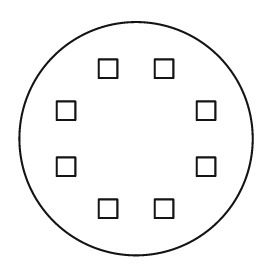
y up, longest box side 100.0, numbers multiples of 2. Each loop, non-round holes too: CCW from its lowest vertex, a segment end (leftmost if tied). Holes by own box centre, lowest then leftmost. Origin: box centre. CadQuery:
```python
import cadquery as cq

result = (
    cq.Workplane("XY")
    .moveTo(0.0, 0.0)
    .circle(50.0)
    .moveTo(-16.0, -34.0)
    .lineTo(-8.0, -34.0)
    .lineTo(-8.0, -26.0)
    .lineTo(-16.0, -26.0)
    .close()
    .moveTo(8.0, -34.0)
    .lineTo(16.0, -34.0)
    .lineTo(16.0, -26.0)
    .lineTo(8.0, -26.0)
    .close()
    .moveTo(-34.0, -16.0)
    .lineTo(-26.0, -16.0)
    .lineTo(-26.0, -8.0)
    .lineTo(-34.0, -8.0)
    .close()
    .moveTo(26.0, -16.0)
    .lineTo(34.0, -16.0)
    .lineTo(34.0, -8.0)
    .lineTo(26.0, -8.0)
    .close()
    .moveTo(-34.0, 8.0)
    .lineTo(-26.0, 8.0)
    .lineTo(-26.0, 16.0)
    .lineTo(-34.0, 16.0)
    .close()
    .moveTo(26.0, 8.0)
    .lineTo(34.0, 8.0)
    .lineTo(34.0, 16.0)
    .lineTo(26.0, 16.0)
    .close()
    .moveTo(-16.0, 26.0)
    .lineTo(-8.0, 26.0)
    .lineTo(-8.0, 34.0)
    .lineTo(-16.0, 34.0)
    .close()
    .moveTo(8.0, 26.0)
    .lineTo(16.0, 26.0)
    .lineTo(16.0, 34.0)
    .lineTo(8.0, 34.0)
    .close()
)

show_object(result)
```